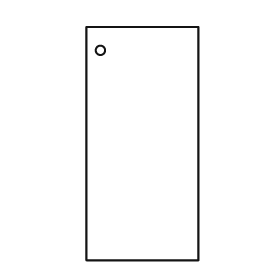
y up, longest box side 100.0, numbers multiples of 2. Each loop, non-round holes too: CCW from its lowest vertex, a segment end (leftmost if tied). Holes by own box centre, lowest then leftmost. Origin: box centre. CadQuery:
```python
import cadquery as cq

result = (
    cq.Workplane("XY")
    .moveTo(-24.0, -50.0)
    .lineTo(24.0, -50.0)
    .lineTo(24.0, 50.0)
    .lineTo(-24.0, 50.0)
    .close()
    .moveTo(-18.0, 40.0)
    .circle(2.0)
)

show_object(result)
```